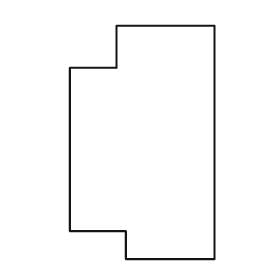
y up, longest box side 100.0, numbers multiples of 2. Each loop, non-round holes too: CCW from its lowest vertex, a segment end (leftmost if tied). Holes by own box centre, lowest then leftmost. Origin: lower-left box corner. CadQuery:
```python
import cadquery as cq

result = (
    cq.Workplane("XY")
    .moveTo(24.0, 0.0)
    .lineTo(62.0, 0.0)
    .lineTo(62.0, 100.0)
    .lineTo(20.0, 100.0)
    .lineTo(20.0, 82.0)
    .lineTo(0.0, 82.0)
    .lineTo(0.0, 12.0)
    .lineTo(24.0, 12.0)
    .close()
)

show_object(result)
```